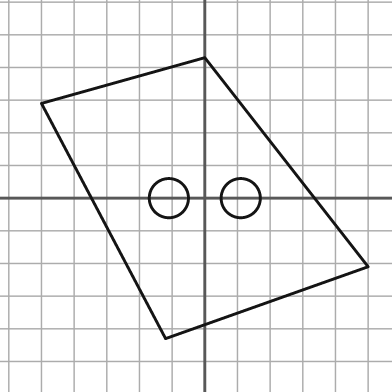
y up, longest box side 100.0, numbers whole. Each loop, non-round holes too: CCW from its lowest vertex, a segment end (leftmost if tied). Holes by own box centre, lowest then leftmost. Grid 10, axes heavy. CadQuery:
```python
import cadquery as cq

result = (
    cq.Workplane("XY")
    .moveTo(-12.0, -43.0)
    .lineTo(50.0, -21.0)
    .lineTo(0.0, 43.0)
    .lineTo(-50.0, 29.0)
    .close()
    .moveTo(-11.0, 0.0)
    .circle(6.0)
    .moveTo(11.0, 0.0)
    .circle(6.0)
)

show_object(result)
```